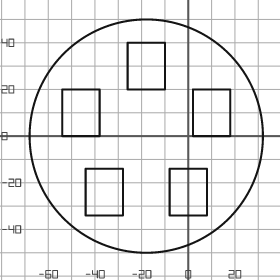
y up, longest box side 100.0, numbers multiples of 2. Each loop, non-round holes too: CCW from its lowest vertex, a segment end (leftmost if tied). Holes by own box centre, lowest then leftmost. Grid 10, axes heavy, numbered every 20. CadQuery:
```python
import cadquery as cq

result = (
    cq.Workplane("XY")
    .moveTo(-18.0, 0.0)
    .circle(50.0)
    .moveTo(-44.0, -34.0)
    .lineTo(-28.0, -34.0)
    .lineTo(-28.0, -14.0)
    .lineTo(-44.0, -14.0)
    .close()
    .moveTo(-8.0, -34.0)
    .lineTo(8.0, -34.0)
    .lineTo(8.0, -14.0)
    .lineTo(-8.0, -14.0)
    .close()
    .moveTo(-54.0, 0.0)
    .lineTo(-38.0, 0.0)
    .lineTo(-38.0, 20.0)
    .lineTo(-54.0, 20.0)
    .close()
    .moveTo(2.0, 0.0)
    .lineTo(18.0, 0.0)
    .lineTo(18.0, 20.0)
    .lineTo(2.0, 20.0)
    .close()
    .moveTo(-26.0, 20.0)
    .lineTo(-10.0, 20.0)
    .lineTo(-10.0, 40.0)
    .lineTo(-26.0, 40.0)
    .close()
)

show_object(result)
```